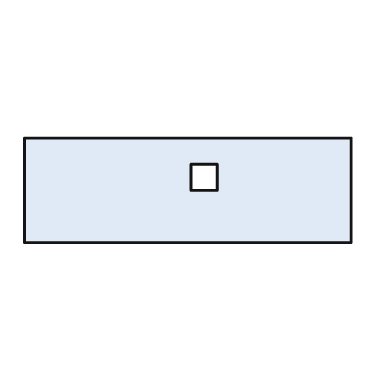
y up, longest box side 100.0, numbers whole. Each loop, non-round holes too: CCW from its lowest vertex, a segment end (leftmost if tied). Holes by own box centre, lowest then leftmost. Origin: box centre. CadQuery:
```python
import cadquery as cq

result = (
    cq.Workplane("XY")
    .moveTo(-50.0, -16.0)
    .lineTo(50.0, -16.0)
    .lineTo(50.0, 16.0)
    .lineTo(-50.0, 16.0)
    .close()
    .moveTo(1.0, 0.0)
    .lineTo(9.0, 0.0)
    .lineTo(9.0, 8.0)
    .lineTo(1.0, 8.0)
    .close()
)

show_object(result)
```